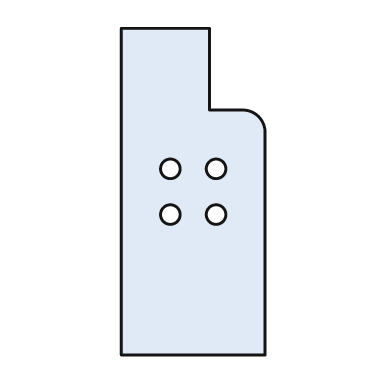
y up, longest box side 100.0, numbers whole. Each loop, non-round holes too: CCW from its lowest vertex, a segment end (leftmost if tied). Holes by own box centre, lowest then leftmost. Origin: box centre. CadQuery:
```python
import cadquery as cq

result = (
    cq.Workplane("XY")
    .moveTo(-22.0, -50.0)
    .lineTo(22.0, -50.0)
    .lineTo(22.0, 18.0)
    .threePointArc((20.0, 23.0), (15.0, 25.0))
    .lineTo(5.0, 25.0)
    .lineTo(5.0, 50.0)
    .lineTo(-22.0, 50.0)
    .close()
    .moveTo(-7.0, -7.0)
    .circle(3.0)
    .moveTo(7.0, -7.0)
    .circle(3.0)
    .moveTo(-7.0, 7.0)
    .circle(3.0)
    .moveTo(7.0, 7.0)
    .circle(3.0)
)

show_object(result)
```